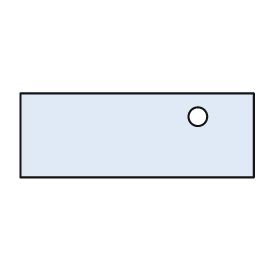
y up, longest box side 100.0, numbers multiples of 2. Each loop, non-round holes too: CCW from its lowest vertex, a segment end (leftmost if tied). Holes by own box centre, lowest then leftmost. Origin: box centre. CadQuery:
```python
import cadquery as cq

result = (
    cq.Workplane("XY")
    .moveTo(-50.0, -18.0)
    .lineTo(50.0, -18.0)
    .lineTo(50.0, 18.0)
    .lineTo(-50.0, 18.0)
    .close()
    .moveTo(26.0, 8.0)
    .circle(4.0)
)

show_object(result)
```